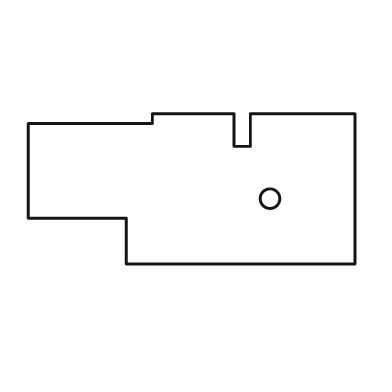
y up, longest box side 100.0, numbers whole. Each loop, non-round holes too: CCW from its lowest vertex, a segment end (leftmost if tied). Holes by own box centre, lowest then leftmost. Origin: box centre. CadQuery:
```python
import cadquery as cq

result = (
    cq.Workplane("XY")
    .moveTo(-20.0, -23.0)
    .lineTo(50.0, -23.0)
    .lineTo(50.0, 23.0)
    .lineTo(18.0, 23.0)
    .lineTo(18.0, 13.0)
    .lineTo(13.0, 13.0)
    .lineTo(13.0, 23.0)
    .lineTo(-12.0, 23.0)
    .lineTo(-12.0, 20.0)
    .lineTo(-50.0, 20.0)
    .lineTo(-50.0, -9.0)
    .lineTo(-20.0, -9.0)
    .close()
    .moveTo(24.0, -3.0)
    .circle(3.0)
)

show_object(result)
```